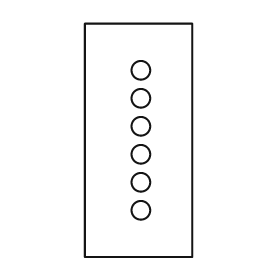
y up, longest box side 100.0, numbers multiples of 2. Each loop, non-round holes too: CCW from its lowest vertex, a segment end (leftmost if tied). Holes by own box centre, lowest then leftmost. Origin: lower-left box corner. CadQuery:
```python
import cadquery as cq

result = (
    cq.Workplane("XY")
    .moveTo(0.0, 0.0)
    .lineTo(46.0, 0.0)
    .lineTo(46.0, 100.0)
    .lineTo(0.0, 100.0)
    .close()
    .moveTo(24.0, 20.0)
    .circle(4.0)
    .moveTo(24.0, 32.0)
    .circle(4.0)
    .moveTo(24.0, 44.0)
    .circle(4.0)
    .moveTo(24.0, 56.0)
    .circle(4.0)
    .moveTo(24.0, 68.0)
    .circle(4.0)
    .moveTo(24.0, 80.0)
    .circle(4.0)
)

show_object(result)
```